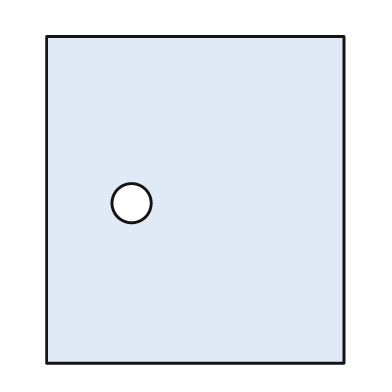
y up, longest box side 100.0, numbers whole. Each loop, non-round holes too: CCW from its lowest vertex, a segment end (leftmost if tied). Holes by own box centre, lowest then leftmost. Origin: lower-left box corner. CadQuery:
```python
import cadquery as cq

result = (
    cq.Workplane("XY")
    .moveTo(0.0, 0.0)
    .lineTo(91.0, 0.0)
    .lineTo(91.0, 100.0)
    .lineTo(0.0, 100.0)
    .close()
    .moveTo(26.0, 49.0)
    .circle(6.0)
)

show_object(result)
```